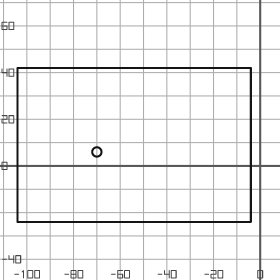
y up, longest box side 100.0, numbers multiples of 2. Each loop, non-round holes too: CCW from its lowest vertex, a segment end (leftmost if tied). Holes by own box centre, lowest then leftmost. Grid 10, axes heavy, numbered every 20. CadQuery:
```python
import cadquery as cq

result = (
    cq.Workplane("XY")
    .moveTo(-104.0, -24.0)
    .lineTo(-4.0, -24.0)
    .lineTo(-4.0, 42.0)
    .lineTo(-104.0, 42.0)
    .close()
    .moveTo(-70.0, 6.0)
    .circle(2.0)
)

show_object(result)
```